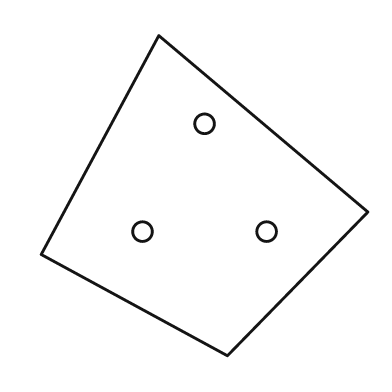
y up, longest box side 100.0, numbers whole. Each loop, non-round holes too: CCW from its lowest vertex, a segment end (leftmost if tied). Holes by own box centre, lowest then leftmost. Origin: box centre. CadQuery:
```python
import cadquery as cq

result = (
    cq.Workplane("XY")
    .moveTo(7.0, -49.0)
    .lineTo(50.0, -5.0)
    .lineTo(-14.0, 49.0)
    .lineTo(-50.0, -18.0)
    .close()
    .moveTo(-19.0, -11.0)
    .circle(3.0)
    .moveTo(19.0, -11.0)
    .circle(3.0)
    .moveTo(0.0, 22.0)
    .circle(3.0)
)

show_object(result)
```